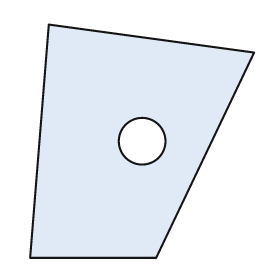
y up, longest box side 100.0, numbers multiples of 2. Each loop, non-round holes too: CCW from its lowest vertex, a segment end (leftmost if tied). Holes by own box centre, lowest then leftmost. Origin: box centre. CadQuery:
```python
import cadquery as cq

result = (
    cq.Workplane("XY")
    .moveTo(-48.0, -50.0)
    .lineTo(6.0, -50.0)
    .lineTo(48.0, 38.0)
    .lineTo(-40.0, 50.0)
    .close()
    .moveTo(0.0, 0.0)
    .circle(10.0)
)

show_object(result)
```